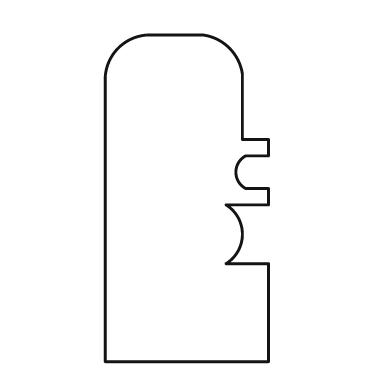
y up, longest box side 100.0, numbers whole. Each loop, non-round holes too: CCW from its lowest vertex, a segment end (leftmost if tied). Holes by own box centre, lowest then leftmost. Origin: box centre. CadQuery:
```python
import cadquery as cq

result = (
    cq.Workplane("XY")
    .moveTo(-25.0, -50.0)
    .lineTo(25.0, -50.0)
    .lineTo(25.0, -20.0)
    .lineTo(12.0, -20.0)
    .threePointArc((17.0, -11.0), (12.0, -2.0))
    .lineTo(25.0, -2.0)
    .lineTo(25.0, 3.0)
    .lineTo(18.0, 3.0)
    .threePointArc((15.0, 8.0), (18.0, 13.0))
    .lineTo(25.0, 13.0)
    .lineTo(25.0, 18.0)
    .lineTo(17.0, 18.0)
    .lineTo(17.0, 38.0)
    .threePointArc((13.0, 46.0), (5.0, 50.0))
    .lineTo(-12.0, 50.0)
    .threePointArc((-21.0, 46.0), (-25.0, 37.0))
    .close()
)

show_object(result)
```